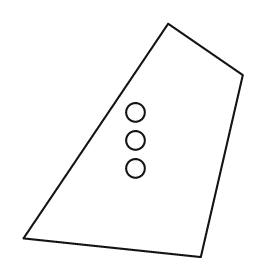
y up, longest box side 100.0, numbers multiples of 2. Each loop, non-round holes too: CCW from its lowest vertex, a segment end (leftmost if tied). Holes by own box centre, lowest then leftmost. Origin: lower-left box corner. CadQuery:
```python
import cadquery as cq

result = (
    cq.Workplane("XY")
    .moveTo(76.0, 0.0)
    .lineTo(94.0, 78.0)
    .lineTo(62.0, 100.0)
    .lineTo(0.0, 8.0)
    .close()
    .moveTo(48.0, 38.0)
    .circle(4.0)
    .moveTo(48.0, 50.0)
    .circle(4.0)
    .moveTo(48.0, 62.0)
    .circle(4.0)
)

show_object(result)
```